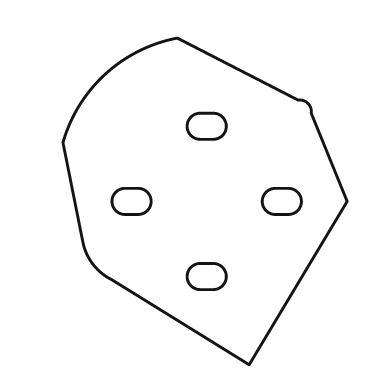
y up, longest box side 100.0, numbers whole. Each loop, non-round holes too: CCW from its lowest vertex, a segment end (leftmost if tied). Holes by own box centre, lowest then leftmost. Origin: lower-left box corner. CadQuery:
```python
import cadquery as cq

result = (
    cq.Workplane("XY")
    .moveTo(57.0, 0.0)
    .lineTo(87.0, 50.0)
    .lineTo(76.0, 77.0)
    .threePointArc((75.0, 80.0), (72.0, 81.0))
    .lineTo(35.0, 100.0)
    .threePointArc((13.0, 89.0), (0.0, 68.0))
    .lineTo(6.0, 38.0)
    .threePointArc((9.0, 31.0), (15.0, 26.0))
    .close()
    .moveTo(42.0, 23.0)
    .lineTo(46.0, 23.0)
    .threePointArc((50.0, 27.0), (46.0, 31.0))
    .lineTo(42.0, 31.0)
    .threePointArc((38.0, 27.0), (42.0, 23.0))
    .close()
    .moveTo(19.0, 46.0)
    .lineTo(23.0, 46.0)
    .threePointArc((27.0, 50.0), (23.0, 54.0))
    .lineTo(19.0, 54.0)
    .threePointArc((15.0, 50.0), (19.0, 46.0))
    .close()
    .moveTo(65.0, 46.0)
    .lineTo(69.0, 46.0)
    .threePointArc((73.0, 50.0), (69.0, 54.0))
    .lineTo(65.0, 54.0)
    .threePointArc((61.0, 50.0), (65.0, 46.0))
    .close()
    .moveTo(42.0, 69.0)
    .lineTo(46.0, 69.0)
    .threePointArc((50.0, 73.0), (46.0, 77.0))
    .lineTo(42.0, 77.0)
    .threePointArc((38.0, 73.0), (42.0, 69.0))
    .close()
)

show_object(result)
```